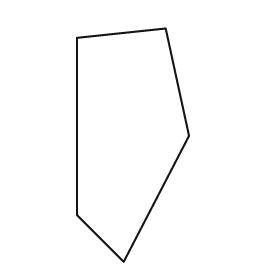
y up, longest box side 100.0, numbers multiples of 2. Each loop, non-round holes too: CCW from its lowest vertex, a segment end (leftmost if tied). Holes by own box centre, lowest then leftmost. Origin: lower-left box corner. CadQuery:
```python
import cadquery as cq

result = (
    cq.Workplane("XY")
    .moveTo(20.0, 0.0)
    .lineTo(48.0, 54.0)
    .lineTo(38.0, 100.0)
    .lineTo(0.0, 96.0)
    .lineTo(0.0, 20.0)
    .close()
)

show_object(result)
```